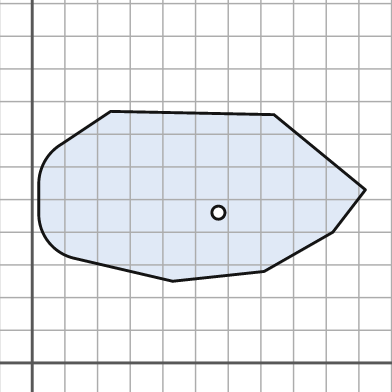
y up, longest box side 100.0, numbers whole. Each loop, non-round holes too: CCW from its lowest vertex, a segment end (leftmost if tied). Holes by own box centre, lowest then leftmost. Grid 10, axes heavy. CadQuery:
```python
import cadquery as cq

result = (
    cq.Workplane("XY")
    .moveTo(43.0, 25.0)
    .lineTo(71.0, 28.0)
    .lineTo(92.0, 40.0)
    .lineTo(102.0, 53.0)
    .lineTo(74.0, 76.0)
    .lineTo(24.0, 77.0)
    .lineTo(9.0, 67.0)
    .threePointArc((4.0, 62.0), (2.0, 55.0))
    .lineTo(2.0, 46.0)
    .threePointArc((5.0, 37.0), (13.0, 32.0))
    .close()
    .moveTo(57.0, 46.0)
    .circle(2.0)
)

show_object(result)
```